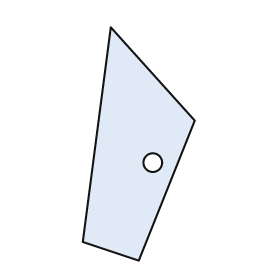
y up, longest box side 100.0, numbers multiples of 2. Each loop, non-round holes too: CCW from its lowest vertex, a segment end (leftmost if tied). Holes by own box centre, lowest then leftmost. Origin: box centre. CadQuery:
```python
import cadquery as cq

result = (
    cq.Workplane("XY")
    .moveTo(0.0, -50.0)
    .lineTo(24.0, 10.0)
    .lineTo(-12.0, 50.0)
    .lineTo(-24.0, -42.0)
    .close()
    .moveTo(6.0, -8.0)
    .circle(4.0)
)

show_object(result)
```